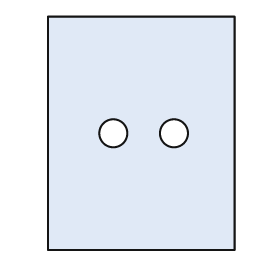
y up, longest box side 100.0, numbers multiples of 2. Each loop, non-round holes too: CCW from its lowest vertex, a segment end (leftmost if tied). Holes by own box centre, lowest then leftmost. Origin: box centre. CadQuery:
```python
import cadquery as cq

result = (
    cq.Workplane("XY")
    .moveTo(-40.0, -50.0)
    .lineTo(40.0, -50.0)
    .lineTo(40.0, 50.0)
    .lineTo(-40.0, 50.0)
    .close()
    .moveTo(-12.0, 0.0)
    .circle(6.0)
    .moveTo(14.0, 0.0)
    .circle(6.0)
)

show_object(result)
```